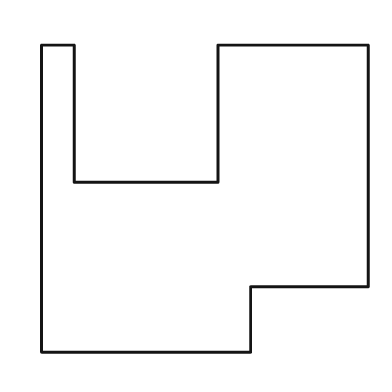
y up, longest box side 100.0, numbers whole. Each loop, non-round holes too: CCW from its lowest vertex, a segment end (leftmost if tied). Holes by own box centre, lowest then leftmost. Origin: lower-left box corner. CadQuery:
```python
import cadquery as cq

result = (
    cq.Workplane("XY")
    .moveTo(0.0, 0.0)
    .lineTo(64.0, 0.0)
    .lineTo(64.0, 20.0)
    .lineTo(100.0, 20.0)
    .lineTo(100.0, 94.0)
    .lineTo(54.0, 94.0)
    .lineTo(54.0, 52.0)
    .lineTo(10.0, 52.0)
    .lineTo(10.0, 94.0)
    .lineTo(0.0, 94.0)
    .close()
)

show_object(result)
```